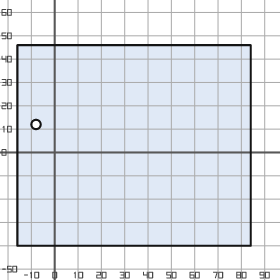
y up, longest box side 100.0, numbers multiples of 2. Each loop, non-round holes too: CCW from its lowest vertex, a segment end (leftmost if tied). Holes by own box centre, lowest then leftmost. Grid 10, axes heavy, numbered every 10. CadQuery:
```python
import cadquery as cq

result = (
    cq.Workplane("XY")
    .moveTo(-16.0, -40.0)
    .lineTo(84.0, -40.0)
    .lineTo(84.0, 46.0)
    .lineTo(-16.0, 46.0)
    .close()
    .moveTo(-8.0, 12.0)
    .circle(2.0)
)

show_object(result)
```